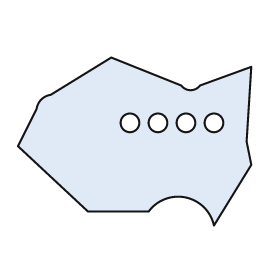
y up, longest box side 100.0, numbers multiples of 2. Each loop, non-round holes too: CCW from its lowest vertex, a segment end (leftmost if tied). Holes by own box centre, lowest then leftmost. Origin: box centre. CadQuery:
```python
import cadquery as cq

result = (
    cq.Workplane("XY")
    .moveTo(34.0, -36.0)
    .lineTo(50.0, -10.0)
    .lineTo(48.0, 0.0)
    .lineTo(50.0, 32.0)
    .lineTo(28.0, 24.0)
    .threePointArc((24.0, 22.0), (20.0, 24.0))
    .lineTo(-10.0, 36.0)
    .lineTo(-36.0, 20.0)
    .threePointArc((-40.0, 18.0), (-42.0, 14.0))
    .lineTo(-50.0, -2.0)
    .lineTo(-20.0, -30.0)
    .lineTo(6.0, -30.0)
    .threePointArc((22.0, -24.0), (34.0, -36.0))
    .close()
    .moveTo(-2.0, 8.0)
    .circle(4.0)
    .moveTo(10.0, 8.0)
    .circle(4.0)
    .moveTo(22.0, 8.0)
    .circle(4.0)
    .moveTo(34.0, 8.0)
    .circle(4.0)
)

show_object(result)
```